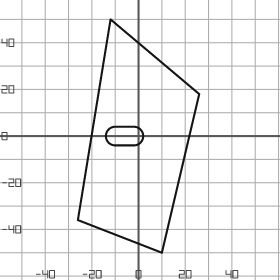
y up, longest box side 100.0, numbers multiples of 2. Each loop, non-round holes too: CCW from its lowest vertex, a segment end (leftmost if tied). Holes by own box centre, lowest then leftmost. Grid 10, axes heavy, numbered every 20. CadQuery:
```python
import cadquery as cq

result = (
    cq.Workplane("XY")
    .moveTo(10.0, -50.0)
    .lineTo(26.0, 18.0)
    .lineTo(-12.0, 50.0)
    .lineTo(-26.0, -36.0)
    .close()
    .moveTo(-10.0, -4.0)
    .lineTo(-2.0, -4.0)
    .threePointArc((2.0, 0.0), (-2.0, 4.0))
    .lineTo(-10.0, 4.0)
    .threePointArc((-14.0, 0.0), (-10.0, -4.0))
    .close()
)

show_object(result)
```